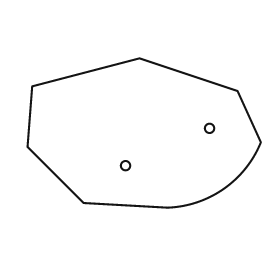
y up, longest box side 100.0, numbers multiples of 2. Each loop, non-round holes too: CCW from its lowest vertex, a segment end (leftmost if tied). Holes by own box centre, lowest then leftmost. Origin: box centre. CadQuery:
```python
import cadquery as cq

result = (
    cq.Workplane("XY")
    .moveTo(10.0, -32.0)
    .threePointArc((34.0, -24.0), (50.0, -4.0))
    .lineTo(40.0, 18.0)
    .lineTo(-2.0, 32.0)
    .lineTo(-48.0, 20.0)
    .lineTo(-50.0, -6.0)
    .lineTo(-26.0, -30.0)
    .close()
    .moveTo(-8.0, -14.0)
    .circle(2.0)
    .moveTo(28.0, 2.0)
    .circle(2.0)
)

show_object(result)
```